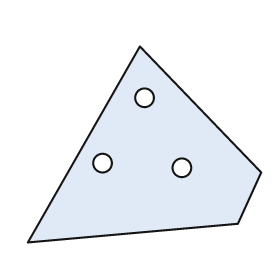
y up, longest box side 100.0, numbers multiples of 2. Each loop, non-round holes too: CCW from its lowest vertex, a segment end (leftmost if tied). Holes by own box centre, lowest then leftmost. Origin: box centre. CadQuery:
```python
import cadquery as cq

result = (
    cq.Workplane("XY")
    .moveTo(-50.0, -42.0)
    .lineTo(40.0, -34.0)
    .lineTo(50.0, -12.0)
    .lineTo(-2.0, 42.0)
    .close()
    .moveTo(16.0, -10.0)
    .circle(4.0)
    .moveTo(-18.0, -8.0)
    .circle(4.0)
    .moveTo(0.0, 20.0)
    .circle(4.0)
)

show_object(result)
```